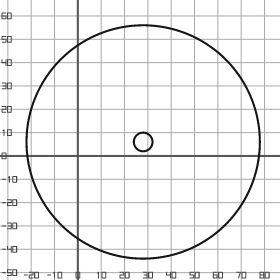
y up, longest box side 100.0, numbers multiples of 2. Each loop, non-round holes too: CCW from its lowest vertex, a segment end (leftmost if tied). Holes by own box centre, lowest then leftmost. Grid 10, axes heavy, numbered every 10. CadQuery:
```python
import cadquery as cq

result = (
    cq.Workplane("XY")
    .moveTo(28.0, 6.0)
    .circle(50.0)
    .moveTo(28.0, 6.0)
    .circle(4.0)
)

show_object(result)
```